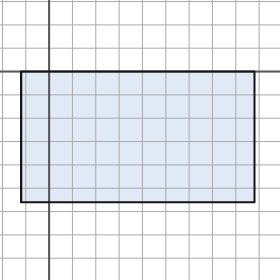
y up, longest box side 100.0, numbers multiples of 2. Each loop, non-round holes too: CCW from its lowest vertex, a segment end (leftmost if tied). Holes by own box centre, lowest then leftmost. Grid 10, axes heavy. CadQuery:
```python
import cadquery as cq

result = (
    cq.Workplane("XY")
    .moveTo(-12.0, -56.0)
    .lineTo(88.0, -56.0)
    .lineTo(88.0, 0.0)
    .lineTo(-12.0, 0.0)
    .close()
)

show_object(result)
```